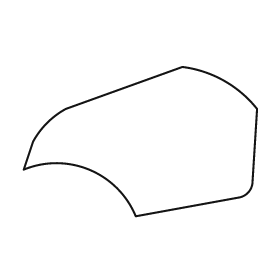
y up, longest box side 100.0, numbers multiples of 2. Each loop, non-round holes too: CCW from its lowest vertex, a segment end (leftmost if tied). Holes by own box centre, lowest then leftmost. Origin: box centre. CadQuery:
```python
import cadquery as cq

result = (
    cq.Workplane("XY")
    .moveTo(-2.0, -32.0)
    .lineTo(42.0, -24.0)
    .threePointArc((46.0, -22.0), (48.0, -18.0))
    .lineTo(50.0, 14.0)
    .threePointArc((36.0, 26.0), (18.0, 32.0))
    .lineTo(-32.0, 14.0)
    .threePointArc((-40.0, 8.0), (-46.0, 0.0))
    .lineTo(-50.0, -12.0)
    .threePointArc((-22.0, -12.0), (-2.0, -32.0))
    .close()
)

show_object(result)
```